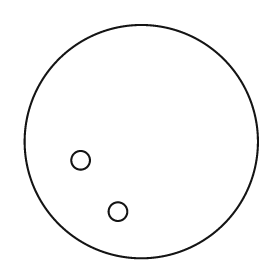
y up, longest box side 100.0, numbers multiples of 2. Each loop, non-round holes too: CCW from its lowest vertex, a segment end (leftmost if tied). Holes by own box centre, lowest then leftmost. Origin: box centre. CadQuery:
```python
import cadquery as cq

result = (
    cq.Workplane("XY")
    .moveTo(0.0, 0.0)
    .circle(50.0)
    .moveTo(-10.0, -30.0)
    .circle(4.0)
    .moveTo(-26.0, -8.0)
    .circle(4.0)
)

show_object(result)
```